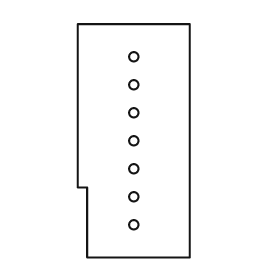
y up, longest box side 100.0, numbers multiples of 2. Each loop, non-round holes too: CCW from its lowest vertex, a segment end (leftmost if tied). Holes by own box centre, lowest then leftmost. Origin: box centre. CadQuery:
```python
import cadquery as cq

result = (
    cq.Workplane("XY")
    .moveTo(-20.0, -50.0)
    .lineTo(24.0, -50.0)
    .lineTo(24.0, 50.0)
    .lineTo(-24.0, 50.0)
    .lineTo(-24.0, -20.0)
    .lineTo(-20.0, -20.0)
    .close()
    .moveTo(0.0, -36.0)
    .circle(2.0)
    .moveTo(0.0, -24.0)
    .circle(2.0)
    .moveTo(0.0, -12.0)
    .circle(2.0)
    .moveTo(0.0, 0.0)
    .circle(2.0)
    .moveTo(0.0, 12.0)
    .circle(2.0)
    .moveTo(0.0, 24.0)
    .circle(2.0)
    .moveTo(0.0, 36.0)
    .circle(2.0)
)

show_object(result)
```